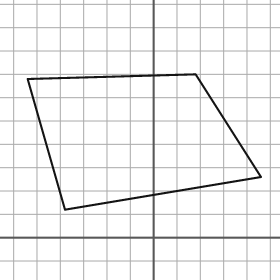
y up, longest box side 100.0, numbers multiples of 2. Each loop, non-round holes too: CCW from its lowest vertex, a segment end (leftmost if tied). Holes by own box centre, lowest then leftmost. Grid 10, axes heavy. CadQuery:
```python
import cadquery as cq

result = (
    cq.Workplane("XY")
    .moveTo(-38.0, 12.0)
    .lineTo(46.0, 26.0)
    .lineTo(18.0, 70.0)
    .lineTo(-54.0, 68.0)
    .close()
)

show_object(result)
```